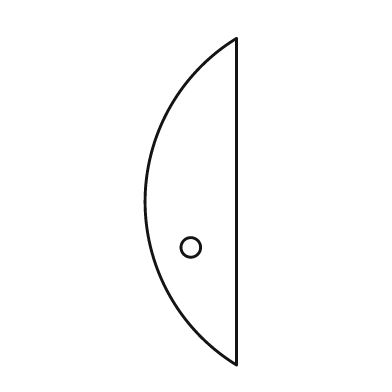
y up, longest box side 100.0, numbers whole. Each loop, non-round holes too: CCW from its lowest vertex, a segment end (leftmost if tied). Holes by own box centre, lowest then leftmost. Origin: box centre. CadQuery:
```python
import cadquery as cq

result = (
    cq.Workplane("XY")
    .moveTo(14.0, -50.0)
    .lineTo(14.0, 50.0)
    .threePointArc((-14.0, 0.0), (14.0, -50.0))
    .close()
    .moveTo(0.0, -14.0)
    .circle(3.0)
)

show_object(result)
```